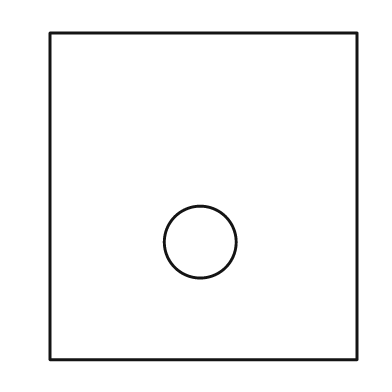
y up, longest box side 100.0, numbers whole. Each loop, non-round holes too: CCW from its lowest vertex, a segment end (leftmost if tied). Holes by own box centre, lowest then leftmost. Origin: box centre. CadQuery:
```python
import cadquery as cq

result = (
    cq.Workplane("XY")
    .moveTo(-47.0, -50.0)
    .lineTo(47.0, -50.0)
    .lineTo(47.0, 50.0)
    .lineTo(-47.0, 50.0)
    .close()
    .moveTo(-1.0, -14.0)
    .circle(11.0)
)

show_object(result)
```